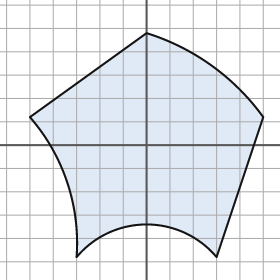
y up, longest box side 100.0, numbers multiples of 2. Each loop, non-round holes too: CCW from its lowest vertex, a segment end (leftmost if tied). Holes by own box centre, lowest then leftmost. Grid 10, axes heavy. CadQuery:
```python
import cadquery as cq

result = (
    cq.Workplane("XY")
    .moveTo(-30.0, -48.0)
    .threePointArc((0.0, -34.0), (30.0, -48.0))
    .lineTo(50.0, 12.0)
    .threePointArc((28.0, 34.0), (0.0, 48.0))
    .lineTo(-50.0, 12.0)
    .threePointArc((-34.0, -16.0), (-30.0, -48.0))
    .close()
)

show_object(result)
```